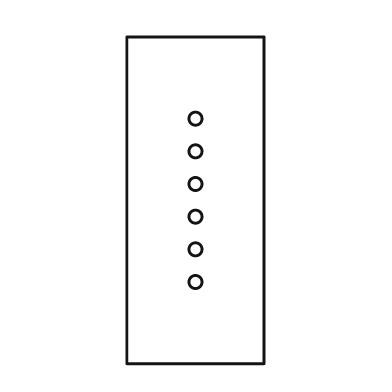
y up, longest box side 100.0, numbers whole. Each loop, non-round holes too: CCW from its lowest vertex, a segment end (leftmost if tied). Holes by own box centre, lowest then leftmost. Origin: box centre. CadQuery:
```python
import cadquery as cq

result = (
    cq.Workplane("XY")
    .moveTo(-21.0, -50.0)
    .lineTo(21.0, -50.0)
    .lineTo(21.0, 50.0)
    .lineTo(-21.0, 50.0)
    .close()
    .moveTo(0.0, -25.0)
    .circle(2.0)
    .moveTo(0.0, -15.0)
    .circle(2.0)
    .moveTo(0.0, -5.0)
    .circle(2.0)
    .moveTo(0.0, 5.0)
    .circle(2.0)
    .moveTo(0.0, 15.0)
    .circle(2.0)
    .moveTo(0.0, 25.0)
    .circle(2.0)
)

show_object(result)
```